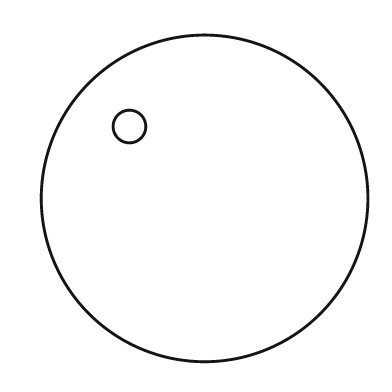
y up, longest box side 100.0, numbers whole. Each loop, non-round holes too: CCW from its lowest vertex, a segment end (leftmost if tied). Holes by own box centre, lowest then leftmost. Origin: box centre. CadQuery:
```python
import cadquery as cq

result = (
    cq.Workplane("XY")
    .moveTo(0.0, 0.0)
    .circle(50.0)
    .moveTo(-23.0, 22.0)
    .circle(5.0)
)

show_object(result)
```